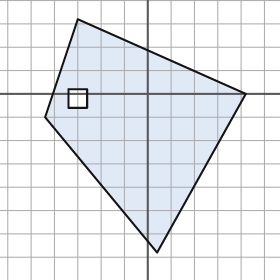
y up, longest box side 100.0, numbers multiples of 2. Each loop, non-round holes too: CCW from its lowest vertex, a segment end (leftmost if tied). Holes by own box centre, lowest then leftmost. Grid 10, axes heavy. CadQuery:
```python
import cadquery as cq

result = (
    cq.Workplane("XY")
    .moveTo(4.0, -68.0)
    .lineTo(42.0, 0.0)
    .lineTo(-30.0, 32.0)
    .lineTo(-44.0, -10.0)
    .close()
    .moveTo(-34.0, -6.0)
    .lineTo(-26.0, -6.0)
    .lineTo(-26.0, 2.0)
    .lineTo(-34.0, 2.0)
    .close()
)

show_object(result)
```